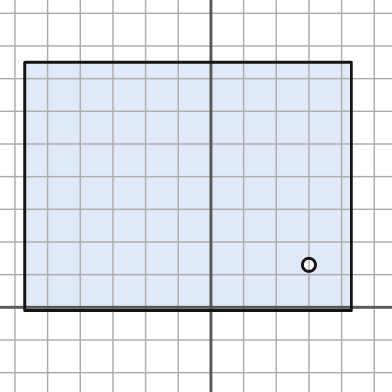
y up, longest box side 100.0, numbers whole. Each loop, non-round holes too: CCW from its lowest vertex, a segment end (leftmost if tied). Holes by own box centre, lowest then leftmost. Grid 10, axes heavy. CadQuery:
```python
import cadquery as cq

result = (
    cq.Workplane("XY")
    .moveTo(-57.0, -1.0)
    .lineTo(43.0, -1.0)
    .lineTo(43.0, 75.0)
    .lineTo(-57.0, 75.0)
    .close()
    .moveTo(30.0, 13.0)
    .circle(2.0)
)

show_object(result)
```